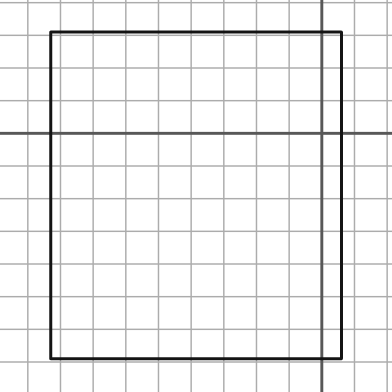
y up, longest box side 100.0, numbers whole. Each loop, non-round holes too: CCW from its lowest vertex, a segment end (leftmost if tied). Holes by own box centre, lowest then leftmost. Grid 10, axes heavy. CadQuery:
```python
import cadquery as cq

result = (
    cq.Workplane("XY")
    .moveTo(-83.0, -69.0)
    .lineTo(6.0, -69.0)
    .lineTo(6.0, 31.0)
    .lineTo(-83.0, 31.0)
    .close()
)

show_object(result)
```